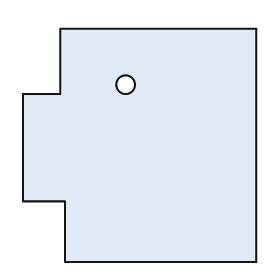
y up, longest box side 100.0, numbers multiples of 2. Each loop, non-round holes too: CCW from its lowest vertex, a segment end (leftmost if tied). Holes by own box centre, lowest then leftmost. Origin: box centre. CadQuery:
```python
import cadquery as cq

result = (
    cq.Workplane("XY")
    .moveTo(-32.0, -50.0)
    .lineTo(50.0, -50.0)
    .lineTo(50.0, 50.0)
    .lineTo(-34.0, 50.0)
    .lineTo(-34.0, 22.0)
    .lineTo(-50.0, 22.0)
    .lineTo(-50.0, -24.0)
    .lineTo(-32.0, -24.0)
    .close()
    .moveTo(-6.0, 26.0)
    .circle(4.0)
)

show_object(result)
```